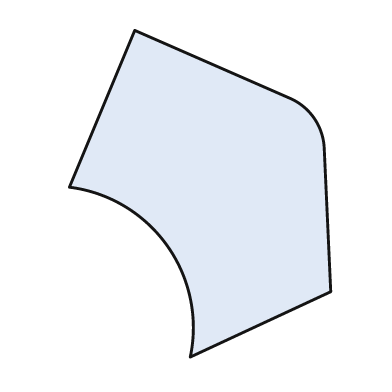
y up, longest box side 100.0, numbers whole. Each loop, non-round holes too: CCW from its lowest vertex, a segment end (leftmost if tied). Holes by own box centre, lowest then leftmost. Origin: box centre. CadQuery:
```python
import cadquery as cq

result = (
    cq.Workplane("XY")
    .moveTo(-3.0, -50.0)
    .lineTo(40.0, -30.0)
    .lineTo(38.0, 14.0)
    .threePointArc((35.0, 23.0), (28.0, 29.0))
    .lineTo(-20.0, 50.0)
    .lineTo(-40.0, 2.0)
    .threePointArc((-10.0, -16.0), (-3.0, -50.0))
    .close()
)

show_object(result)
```